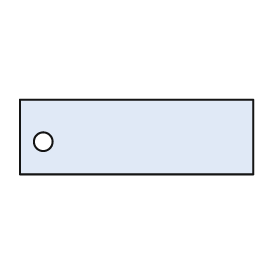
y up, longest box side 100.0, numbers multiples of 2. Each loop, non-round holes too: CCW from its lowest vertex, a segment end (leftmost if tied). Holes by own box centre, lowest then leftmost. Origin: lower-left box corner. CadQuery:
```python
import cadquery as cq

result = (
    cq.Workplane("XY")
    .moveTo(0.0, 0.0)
    .lineTo(100.0, 0.0)
    .lineTo(100.0, 32.0)
    .lineTo(0.0, 32.0)
    .close()
    .moveTo(10.0, 14.0)
    .circle(4.0)
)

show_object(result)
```